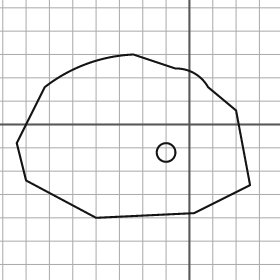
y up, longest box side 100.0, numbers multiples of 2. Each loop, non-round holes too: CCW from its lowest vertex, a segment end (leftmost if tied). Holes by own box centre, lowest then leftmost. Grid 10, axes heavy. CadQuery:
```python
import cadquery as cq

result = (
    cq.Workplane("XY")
    .moveTo(-40.0, -40.0)
    .lineTo(2.0, -38.0)
    .lineTo(26.0, -26.0)
    .lineTo(20.0, 6.0)
    .lineTo(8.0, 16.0)
    .threePointArc((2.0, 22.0), (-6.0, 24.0))
    .lineTo(-24.0, 30.0)
    .threePointArc((-44.0, 26.0), (-62.0, 16.0))
    .lineTo(-74.0, -8.0)
    .lineTo(-70.0, -24.0)
    .close()
    .moveTo(-10.0, -12.0)
    .circle(4.0)
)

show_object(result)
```